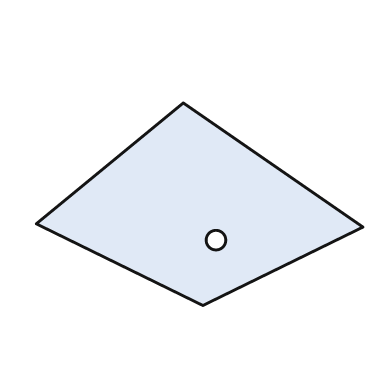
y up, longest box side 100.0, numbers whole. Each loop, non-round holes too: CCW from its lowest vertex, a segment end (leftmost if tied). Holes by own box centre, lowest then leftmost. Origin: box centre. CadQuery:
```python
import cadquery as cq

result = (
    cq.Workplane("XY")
    .moveTo(1.0, -31.0)
    .lineTo(50.0, -7.0)
    .lineTo(-5.0, 31.0)
    .lineTo(-50.0, -6.0)
    .close()
    .moveTo(5.0, -11.0)
    .circle(3.0)
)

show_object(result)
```